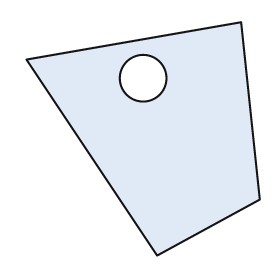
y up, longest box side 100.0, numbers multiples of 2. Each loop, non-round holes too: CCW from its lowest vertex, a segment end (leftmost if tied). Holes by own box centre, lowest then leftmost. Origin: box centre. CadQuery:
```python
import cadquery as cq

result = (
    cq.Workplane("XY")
    .moveTo(6.0, -50.0)
    .lineTo(50.0, -26.0)
    .lineTo(42.0, 50.0)
    .lineTo(-50.0, 34.0)
    .close()
    .moveTo(0.0, 26.0)
    .circle(10.0)
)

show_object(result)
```